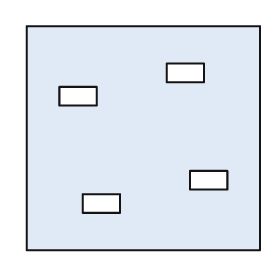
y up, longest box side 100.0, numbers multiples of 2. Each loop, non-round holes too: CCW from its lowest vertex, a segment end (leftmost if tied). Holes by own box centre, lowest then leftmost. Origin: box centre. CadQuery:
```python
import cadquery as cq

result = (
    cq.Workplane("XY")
    .moveTo(-50.0, -48.0)
    .lineTo(50.0, -48.0)
    .lineTo(50.0, 48.0)
    .lineTo(-50.0, 48.0)
    .close()
    .moveTo(-26.0, -32.0)
    .lineTo(-10.0, -32.0)
    .lineTo(-10.0, -24.0)
    .lineTo(-26.0, -24.0)
    .close()
    .moveTo(20.0, -22.0)
    .lineTo(36.0, -22.0)
    .lineTo(36.0, -14.0)
    .lineTo(20.0, -14.0)
    .close()
    .moveTo(-36.0, 14.0)
    .lineTo(-20.0, 14.0)
    .lineTo(-20.0, 22.0)
    .lineTo(-36.0, 22.0)
    .close()
    .moveTo(10.0, 24.0)
    .lineTo(26.0, 24.0)
    .lineTo(26.0, 32.0)
    .lineTo(10.0, 32.0)
    .close()
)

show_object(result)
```